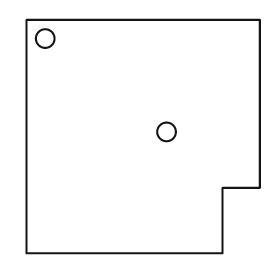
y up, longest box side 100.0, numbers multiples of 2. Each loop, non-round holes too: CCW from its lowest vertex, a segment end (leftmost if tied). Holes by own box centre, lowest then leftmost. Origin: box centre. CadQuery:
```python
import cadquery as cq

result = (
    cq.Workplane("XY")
    .moveTo(-50.0, -50.0)
    .lineTo(34.0, -50.0)
    .lineTo(34.0, -22.0)
    .lineTo(50.0, -22.0)
    .lineTo(50.0, 50.0)
    .lineTo(-50.0, 50.0)
    .close()
    .moveTo(10.0, 2.0)
    .circle(4.0)
    .moveTo(-42.0, 42.0)
    .circle(4.0)
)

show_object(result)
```